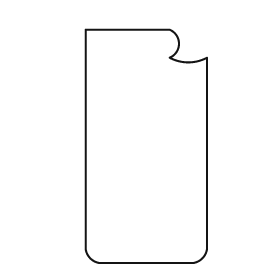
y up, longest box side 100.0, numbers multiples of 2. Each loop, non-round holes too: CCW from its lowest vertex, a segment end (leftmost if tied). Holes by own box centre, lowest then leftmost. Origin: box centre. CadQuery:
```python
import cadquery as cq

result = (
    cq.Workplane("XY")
    .moveTo(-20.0, -50.0)
    .lineTo(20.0, -50.0)
    .threePointArc((24.0, -48.0), (26.0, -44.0))
    .lineTo(26.0, 38.0)
    .threePointArc((18.0, 36.0), (10.0, 38.0))
    .threePointArc((14.0, 44.0), (10.0, 50.0))
    .lineTo(-26.0, 50.0)
    .lineTo(-26.0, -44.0)
    .threePointArc((-24.0, -48.0), (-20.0, -50.0))
    .close()
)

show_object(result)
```